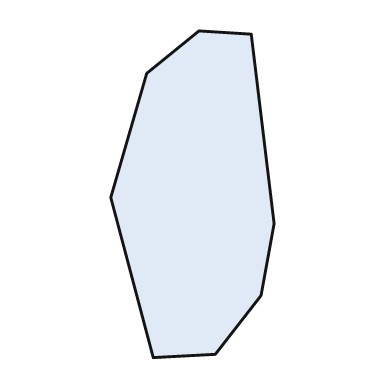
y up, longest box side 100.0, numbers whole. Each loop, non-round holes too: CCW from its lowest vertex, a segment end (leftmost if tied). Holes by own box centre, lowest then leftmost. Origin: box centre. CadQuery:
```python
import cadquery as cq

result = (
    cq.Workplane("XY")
    .moveTo(-12.0, -50.0)
    .lineTo(7.0, -49.0)
    .lineTo(21.0, -31.0)
    .lineTo(25.0, -9.0)
    .lineTo(18.0, 49.0)
    .lineTo(2.0, 50.0)
    .lineTo(-14.0, 37.0)
    .lineTo(-25.0, -1.0)
    .close()
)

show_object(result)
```